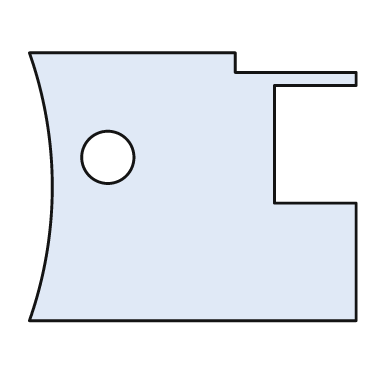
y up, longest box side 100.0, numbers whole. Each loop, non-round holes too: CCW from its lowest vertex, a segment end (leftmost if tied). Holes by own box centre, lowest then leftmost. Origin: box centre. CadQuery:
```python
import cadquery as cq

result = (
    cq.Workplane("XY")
    .moveTo(-50.0, -41.0)
    .lineTo(50.0, -41.0)
    .lineTo(50.0, -5.0)
    .lineTo(25.0, -5.0)
    .lineTo(25.0, 31.0)
    .lineTo(50.0, 31.0)
    .lineTo(50.0, 35.0)
    .lineTo(13.0, 35.0)
    .lineTo(13.0, 41.0)
    .lineTo(-50.0, 41.0)
    .threePointArc((-43.0, 0.0), (-50.0, -41.0))
    .close()
    .moveTo(-26.0, 9.0)
    .circle(8.0)
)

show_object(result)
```